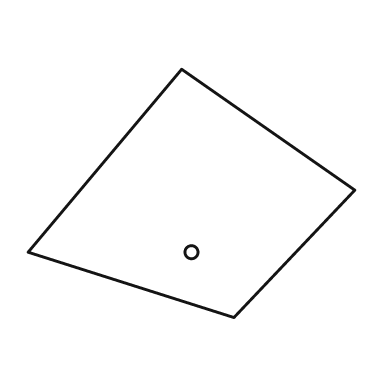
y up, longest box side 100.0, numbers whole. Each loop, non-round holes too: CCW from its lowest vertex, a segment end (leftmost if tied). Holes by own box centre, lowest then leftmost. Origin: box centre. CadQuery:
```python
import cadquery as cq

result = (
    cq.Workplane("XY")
    .moveTo(13.0, -38.0)
    .lineTo(50.0, 1.0)
    .lineTo(-3.0, 38.0)
    .lineTo(-50.0, -18.0)
    .close()
    .moveTo(0.0, -18.0)
    .circle(2.0)
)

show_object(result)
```